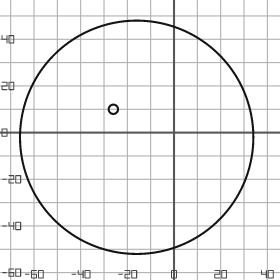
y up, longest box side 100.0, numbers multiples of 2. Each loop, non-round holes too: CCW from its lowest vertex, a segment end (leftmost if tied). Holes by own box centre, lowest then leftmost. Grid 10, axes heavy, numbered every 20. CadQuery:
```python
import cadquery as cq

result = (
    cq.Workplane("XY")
    .moveTo(-16.0, -2.0)
    .circle(50.0)
    .moveTo(-26.0, 10.0)
    .circle(2.0)
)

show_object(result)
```